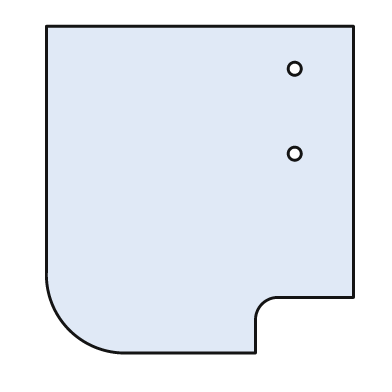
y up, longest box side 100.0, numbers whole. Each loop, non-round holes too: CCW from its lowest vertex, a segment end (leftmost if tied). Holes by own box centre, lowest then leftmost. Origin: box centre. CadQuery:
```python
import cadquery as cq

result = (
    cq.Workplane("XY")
    .moveTo(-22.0, -50.0)
    .lineTo(17.0, -50.0)
    .lineTo(17.0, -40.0)
    .threePointArc((19.0, -35.0), (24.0, -33.0))
    .lineTo(47.0, -33.0)
    .lineTo(47.0, 50.0)
    .lineTo(-47.0, 50.0)
    .lineTo(-47.0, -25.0)
    .threePointArc((-40.0, -43.0), (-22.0, -50.0))
    .close()
    .moveTo(29.0, 11.0)
    .circle(2.0)
    .moveTo(29.0, 37.0)
    .circle(2.0)
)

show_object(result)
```